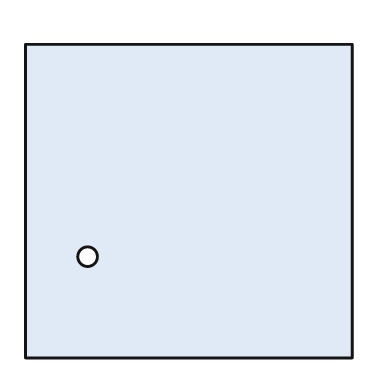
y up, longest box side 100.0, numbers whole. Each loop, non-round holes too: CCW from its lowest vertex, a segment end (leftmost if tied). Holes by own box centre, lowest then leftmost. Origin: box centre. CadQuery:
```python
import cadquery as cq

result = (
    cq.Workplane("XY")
    .moveTo(-50.0, -48.0)
    .lineTo(50.0, -48.0)
    .lineTo(50.0, 48.0)
    .lineTo(-50.0, 48.0)
    .close()
    .moveTo(-31.0, -17.0)
    .circle(3.0)
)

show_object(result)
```